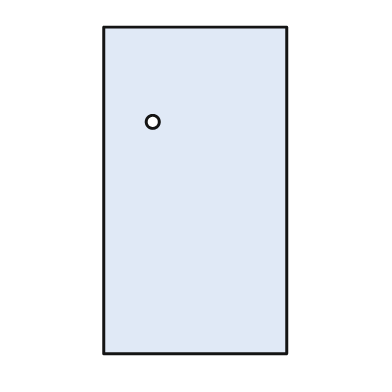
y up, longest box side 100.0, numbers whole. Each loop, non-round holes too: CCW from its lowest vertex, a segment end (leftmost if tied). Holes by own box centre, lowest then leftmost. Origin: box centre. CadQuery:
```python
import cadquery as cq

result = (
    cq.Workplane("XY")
    .moveTo(-28.0, -50.0)
    .lineTo(28.0, -50.0)
    .lineTo(28.0, 50.0)
    .lineTo(-28.0, 50.0)
    .close()
    .moveTo(-13.0, 21.0)
    .circle(2.0)
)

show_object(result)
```